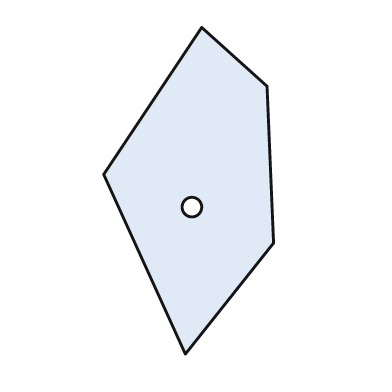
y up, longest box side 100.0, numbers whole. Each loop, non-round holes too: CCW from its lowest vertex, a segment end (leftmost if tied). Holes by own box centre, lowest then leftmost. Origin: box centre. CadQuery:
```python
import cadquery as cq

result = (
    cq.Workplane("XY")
    .moveTo(-1.0, -50.0)
    .lineTo(26.0, -16.0)
    .lineTo(24.0, 32.0)
    .lineTo(4.0, 50.0)
    .lineTo(-26.0, 5.0)
    .close()
    .moveTo(1.0, -5.0)
    .circle(3.0)
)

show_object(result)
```